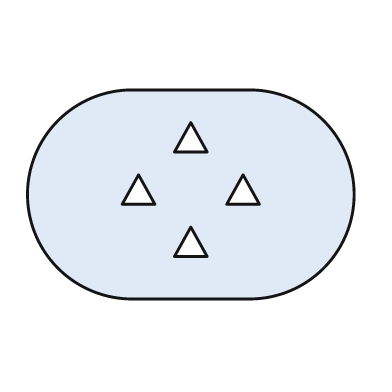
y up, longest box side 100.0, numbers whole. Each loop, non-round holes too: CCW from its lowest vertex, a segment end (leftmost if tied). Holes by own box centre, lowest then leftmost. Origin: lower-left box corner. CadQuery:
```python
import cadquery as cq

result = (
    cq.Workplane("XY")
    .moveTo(32.0, 0.0)
    .lineTo(68.0, 0.0)
    .threePointArc((100.0, 32.0), (68.0, 64.0))
    .lineTo(32.0, 64.0)
    .threePointArc((0.0, 32.0), (32.0, 0.0))
    .close()
    .moveTo(45.0, 13.0)
    .lineTo(55.0, 13.0)
    .lineTo(50.0, 22.0)
    .close()
    .moveTo(29.0, 29.0)
    .lineTo(39.0, 29.0)
    .lineTo(34.0, 38.0)
    .close()
    .moveTo(61.0, 29.0)
    .lineTo(71.0, 29.0)
    .lineTo(66.0, 38.0)
    .close()
    .moveTo(45.0, 45.0)
    .lineTo(55.0, 45.0)
    .lineTo(50.0, 54.0)
    .close()
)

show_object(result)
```